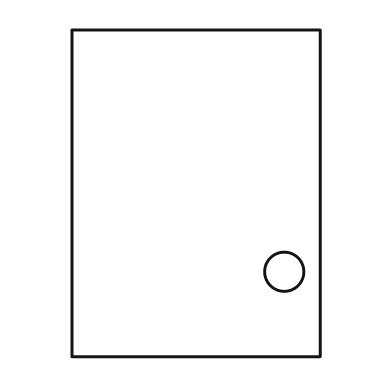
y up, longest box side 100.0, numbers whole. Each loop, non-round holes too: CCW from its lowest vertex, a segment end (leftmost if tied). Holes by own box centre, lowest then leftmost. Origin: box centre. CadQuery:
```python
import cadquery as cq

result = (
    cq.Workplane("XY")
    .moveTo(-38.0, -50.0)
    .lineTo(38.0, -50.0)
    .lineTo(38.0, 50.0)
    .lineTo(-38.0, 50.0)
    .close()
    .moveTo(27.0, -24.0)
    .circle(6.0)
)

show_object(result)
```